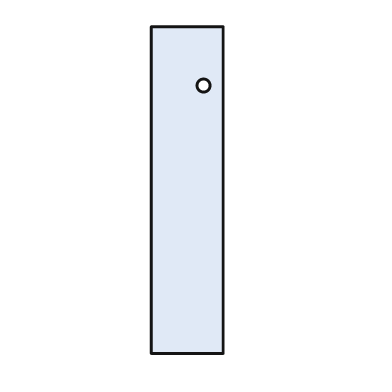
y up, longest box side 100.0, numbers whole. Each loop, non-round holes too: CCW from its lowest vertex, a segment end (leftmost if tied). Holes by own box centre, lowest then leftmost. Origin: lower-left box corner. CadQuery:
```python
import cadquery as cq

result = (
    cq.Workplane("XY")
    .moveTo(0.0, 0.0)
    .lineTo(22.0, 0.0)
    .lineTo(22.0, 100.0)
    .lineTo(0.0, 100.0)
    .close()
    .moveTo(16.0, 82.0)
    .circle(2.0)
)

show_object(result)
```